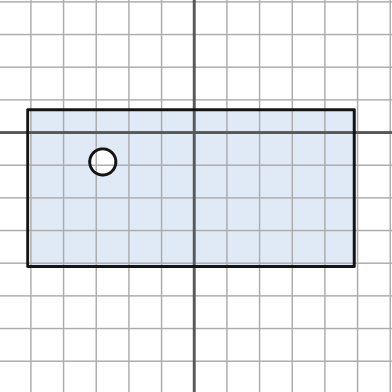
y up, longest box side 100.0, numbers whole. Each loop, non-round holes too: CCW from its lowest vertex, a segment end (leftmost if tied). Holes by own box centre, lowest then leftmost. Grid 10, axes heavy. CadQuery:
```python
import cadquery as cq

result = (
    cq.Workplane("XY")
    .moveTo(-51.0, -41.0)
    .lineTo(49.0, -41.0)
    .lineTo(49.0, 7.0)
    .lineTo(-51.0, 7.0)
    .close()
    .moveTo(-28.0, -9.0)
    .circle(4.0)
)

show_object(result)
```